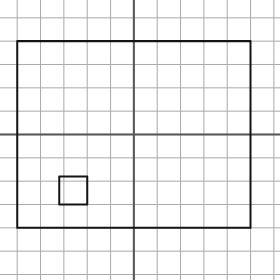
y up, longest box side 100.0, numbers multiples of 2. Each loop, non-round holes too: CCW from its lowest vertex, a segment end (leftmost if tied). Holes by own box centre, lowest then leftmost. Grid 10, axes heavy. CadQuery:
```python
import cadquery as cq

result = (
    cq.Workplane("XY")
    .moveTo(-50.0, -40.0)
    .lineTo(50.0, -40.0)
    .lineTo(50.0, 40.0)
    .lineTo(-50.0, 40.0)
    .close()
    .moveTo(-32.0, -30.0)
    .lineTo(-20.0, -30.0)
    .lineTo(-20.0, -18.0)
    .lineTo(-32.0, -18.0)
    .close()
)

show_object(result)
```